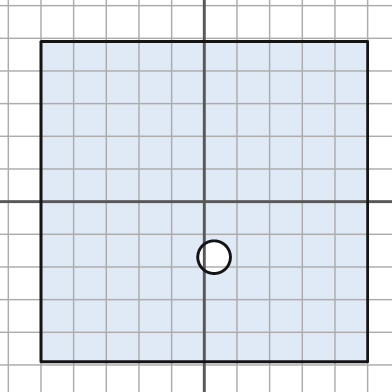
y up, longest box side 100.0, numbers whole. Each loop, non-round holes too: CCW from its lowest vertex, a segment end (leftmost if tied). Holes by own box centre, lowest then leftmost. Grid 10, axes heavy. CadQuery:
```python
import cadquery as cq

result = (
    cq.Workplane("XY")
    .moveTo(-50.0, -49.0)
    .lineTo(50.0, -49.0)
    .lineTo(50.0, 49.0)
    .lineTo(-50.0, 49.0)
    .close()
    .moveTo(3.0, -17.0)
    .circle(5.0)
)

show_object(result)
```